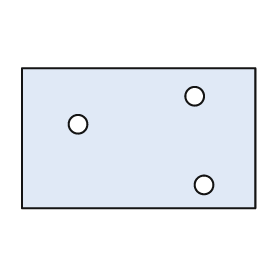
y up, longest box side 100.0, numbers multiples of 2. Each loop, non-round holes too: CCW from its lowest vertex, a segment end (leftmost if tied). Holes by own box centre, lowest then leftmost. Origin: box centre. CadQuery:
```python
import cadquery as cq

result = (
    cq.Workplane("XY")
    .moveTo(-50.0, -30.0)
    .lineTo(50.0, -30.0)
    .lineTo(50.0, 30.0)
    .lineTo(-50.0, 30.0)
    .close()
    .moveTo(28.0, -20.0)
    .circle(4.0)
    .moveTo(-26.0, 6.0)
    .circle(4.0)
    .moveTo(24.0, 18.0)
    .circle(4.0)
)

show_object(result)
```